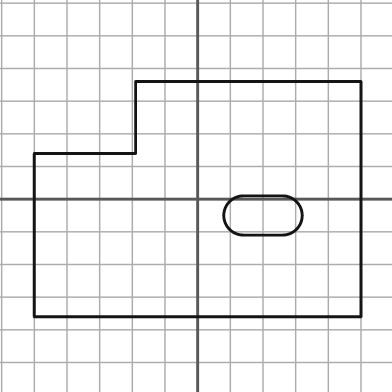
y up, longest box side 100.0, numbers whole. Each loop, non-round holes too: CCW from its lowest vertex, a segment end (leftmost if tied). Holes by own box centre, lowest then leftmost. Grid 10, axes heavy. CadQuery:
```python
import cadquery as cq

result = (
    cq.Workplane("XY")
    .moveTo(-50.0, -36.0)
    .lineTo(50.0, -36.0)
    .lineTo(50.0, 36.0)
    .lineTo(-19.0, 36.0)
    .lineTo(-19.0, 14.0)
    .lineTo(-50.0, 14.0)
    .close()
    .moveTo(14.0, -11.0)
    .lineTo(26.0, -11.0)
    .threePointArc((32.0, -5.0), (26.0, 1.0))
    .lineTo(14.0, 1.0)
    .threePointArc((8.0, -5.0), (14.0, -11.0))
    .close()
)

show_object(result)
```